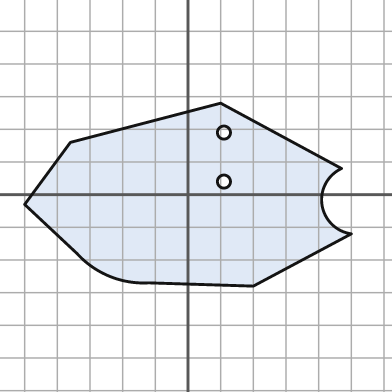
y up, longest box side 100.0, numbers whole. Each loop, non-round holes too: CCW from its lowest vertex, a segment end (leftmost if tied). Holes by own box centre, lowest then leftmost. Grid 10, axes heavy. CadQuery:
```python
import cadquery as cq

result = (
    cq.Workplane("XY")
    .moveTo(20.0, -28.0)
    .lineTo(50.0, -12.0)
    .threePointArc((41.0, -3.0), (47.0, 8.0))
    .lineTo(10.0, 28.0)
    .lineTo(-36.0, 16.0)
    .lineTo(-50.0, -3.0)
    .lineTo(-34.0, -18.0)
    .threePointArc((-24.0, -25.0), (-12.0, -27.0))
    .close()
    .moveTo(11.0, 4.0)
    .circle(2.0)
    .moveTo(11.0, 19.0)
    .circle(2.0)
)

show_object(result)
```